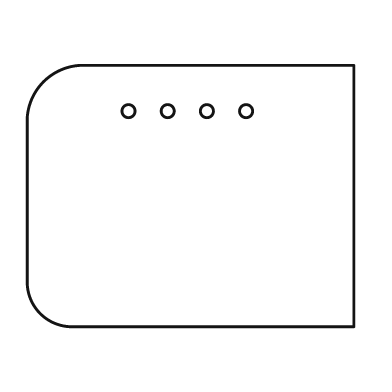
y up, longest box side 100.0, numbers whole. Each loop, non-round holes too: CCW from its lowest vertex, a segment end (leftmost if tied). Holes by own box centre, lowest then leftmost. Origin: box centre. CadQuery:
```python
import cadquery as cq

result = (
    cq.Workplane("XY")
    .moveTo(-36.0, -40.0)
    .lineTo(50.0, -40.0)
    .lineTo(50.0, 40.0)
    .lineTo(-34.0, 40.0)
    .threePointArc((-45.0, 35.0), (-50.0, 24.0))
    .lineTo(-50.0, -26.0)
    .threePointArc((-46.0, -36.0), (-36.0, -40.0))
    .close()
    .moveTo(-19.0, 26.0)
    .circle(2.0)
    .moveTo(-7.0, 26.0)
    .circle(2.0)
    .moveTo(5.0, 26.0)
    .circle(2.0)
    .moveTo(17.0, 26.0)
    .circle(2.0)
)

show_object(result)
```